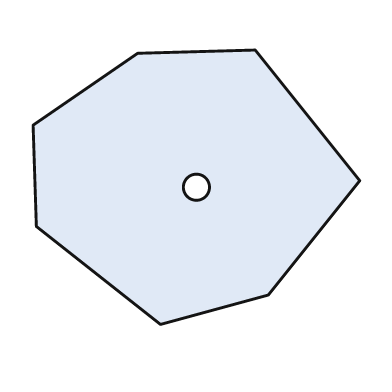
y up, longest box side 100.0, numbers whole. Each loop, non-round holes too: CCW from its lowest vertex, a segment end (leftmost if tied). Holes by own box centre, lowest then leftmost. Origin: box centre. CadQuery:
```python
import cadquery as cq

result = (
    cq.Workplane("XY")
    .moveTo(-11.0, -42.0)
    .lineTo(22.0, -33.0)
    .lineTo(50.0, 2.0)
    .lineTo(18.0, 42.0)
    .lineTo(-18.0, 41.0)
    .lineTo(-50.0, 19.0)
    .lineTo(-49.0, -12.0)
    .close()
    .moveTo(0.0, 0.0)
    .circle(4.0)
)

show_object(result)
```